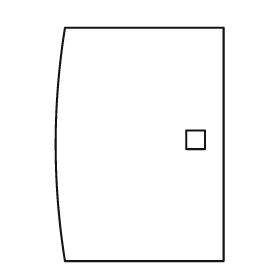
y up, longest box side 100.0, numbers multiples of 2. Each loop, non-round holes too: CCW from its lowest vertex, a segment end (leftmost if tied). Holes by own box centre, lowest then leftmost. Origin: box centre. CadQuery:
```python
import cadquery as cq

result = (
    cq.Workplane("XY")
    .moveTo(-32.0, -50.0)
    .lineTo(36.0, -50.0)
    .lineTo(36.0, 50.0)
    .lineTo(-32.0, 50.0)
    .threePointArc((-36.0, 0.0), (-32.0, -50.0))
    .close()
    .moveTo(20.0, -2.0)
    .lineTo(28.0, -2.0)
    .lineTo(28.0, 6.0)
    .lineTo(20.0, 6.0)
    .close()
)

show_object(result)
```